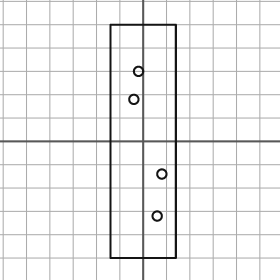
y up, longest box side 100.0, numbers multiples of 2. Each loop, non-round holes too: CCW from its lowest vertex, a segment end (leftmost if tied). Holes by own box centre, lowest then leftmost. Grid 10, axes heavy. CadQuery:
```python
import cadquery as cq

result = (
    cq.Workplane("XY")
    .moveTo(-14.0, -50.0)
    .lineTo(14.0, -50.0)
    .lineTo(14.0, 50.0)
    .lineTo(-14.0, 50.0)
    .close()
    .moveTo(6.0, -32.0)
    .circle(2.0)
    .moveTo(8.0, -14.0)
    .circle(2.0)
    .moveTo(-4.0, 18.0)
    .circle(2.0)
    .moveTo(-2.0, 30.0)
    .circle(2.0)
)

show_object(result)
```